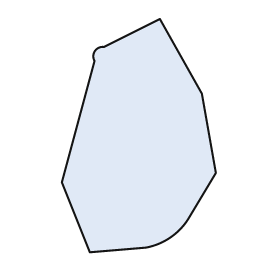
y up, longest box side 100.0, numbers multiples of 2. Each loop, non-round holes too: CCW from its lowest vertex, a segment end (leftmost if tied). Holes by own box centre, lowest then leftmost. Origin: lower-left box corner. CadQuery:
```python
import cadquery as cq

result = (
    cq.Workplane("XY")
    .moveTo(12.0, 0.0)
    .lineTo(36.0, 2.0)
    .threePointArc((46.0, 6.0), (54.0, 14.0))
    .lineTo(66.0, 34.0)
    .lineTo(60.0, 68.0)
    .lineTo(42.0, 100.0)
    .lineTo(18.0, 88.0)
    .threePointArc((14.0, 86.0), (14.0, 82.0))
    .lineTo(0.0, 30.0)
    .close()
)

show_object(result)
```